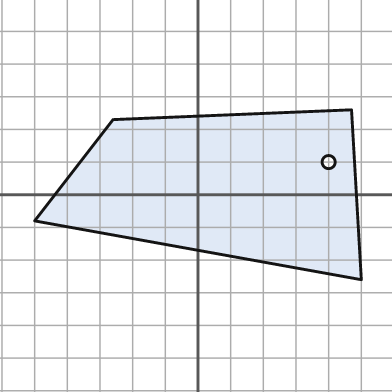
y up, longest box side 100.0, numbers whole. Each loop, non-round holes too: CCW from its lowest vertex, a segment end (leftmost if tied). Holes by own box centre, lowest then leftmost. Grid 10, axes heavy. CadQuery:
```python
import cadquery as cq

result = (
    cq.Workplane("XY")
    .moveTo(50.0, -26.0)
    .lineTo(47.0, 26.0)
    .lineTo(-26.0, 23.0)
    .lineTo(-50.0, -8.0)
    .close()
    .moveTo(40.0, 10.0)
    .circle(2.0)
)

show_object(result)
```